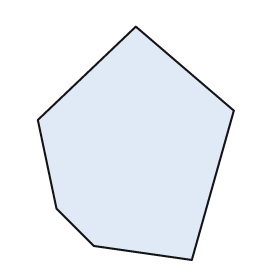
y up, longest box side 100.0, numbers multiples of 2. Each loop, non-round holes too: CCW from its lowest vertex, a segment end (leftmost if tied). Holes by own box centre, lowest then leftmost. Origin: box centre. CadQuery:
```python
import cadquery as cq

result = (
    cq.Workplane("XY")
    .moveTo(24.0, -50.0)
    .lineTo(42.0, 14.0)
    .lineTo(0.0, 50.0)
    .lineTo(-42.0, 10.0)
    .lineTo(-34.0, -28.0)
    .lineTo(-18.0, -44.0)
    .close()
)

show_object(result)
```